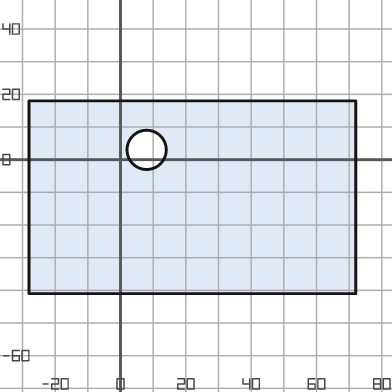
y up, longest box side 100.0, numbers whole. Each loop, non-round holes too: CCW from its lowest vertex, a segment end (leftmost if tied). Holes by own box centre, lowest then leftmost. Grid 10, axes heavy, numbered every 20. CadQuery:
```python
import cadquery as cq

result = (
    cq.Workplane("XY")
    .moveTo(-28.0, -41.0)
    .lineTo(72.0, -41.0)
    .lineTo(72.0, 18.0)
    .lineTo(-28.0, 18.0)
    .close()
    .moveTo(8.0, 3.0)
    .circle(6.0)
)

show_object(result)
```